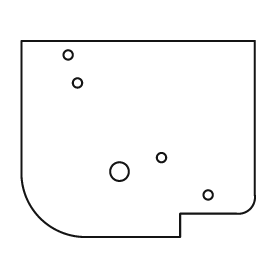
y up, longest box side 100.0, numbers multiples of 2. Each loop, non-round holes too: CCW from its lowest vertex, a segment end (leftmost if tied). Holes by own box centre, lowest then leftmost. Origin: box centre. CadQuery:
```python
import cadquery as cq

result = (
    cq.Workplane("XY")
    .moveTo(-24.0, -42.0)
    .lineTo(18.0, -42.0)
    .lineTo(18.0, -32.0)
    .lineTo(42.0, -32.0)
    .threePointArc((48.0, -30.0), (50.0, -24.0))
    .lineTo(50.0, 42.0)
    .lineTo(-50.0, 42.0)
    .lineTo(-50.0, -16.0)
    .threePointArc((-42.0, -34.0), (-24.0, -42.0))
    .close()
    .moveTo(30.0, -24.0)
    .circle(2.0)
    .moveTo(-8.0, -14.0)
    .circle(4.0)
    .moveTo(10.0, -8.0)
    .circle(2.0)
    .moveTo(-26.0, 24.0)
    .circle(2.0)
    .moveTo(-30.0, 36.0)
    .circle(2.0)
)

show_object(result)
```